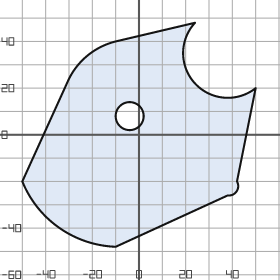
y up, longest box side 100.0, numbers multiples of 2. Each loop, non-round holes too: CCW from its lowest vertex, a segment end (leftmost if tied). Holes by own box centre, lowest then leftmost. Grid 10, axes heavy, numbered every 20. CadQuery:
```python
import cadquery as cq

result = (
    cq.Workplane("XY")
    .moveTo(-10.0, -48.0)
    .lineTo(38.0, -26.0)
    .threePointArc((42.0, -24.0), (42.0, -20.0))
    .lineTo(50.0, 20.0)
    .threePointArc((24.0, 22.0), (24.0, 48.0))
    .lineTo(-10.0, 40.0)
    .threePointArc((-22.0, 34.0), (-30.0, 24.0))
    .lineTo(-50.0, -20.0)
    .threePointArc((-34.0, -40.0), (-10.0, -48.0))
    .close()
    .moveTo(-4.0, 8.0)
    .circle(6.0)
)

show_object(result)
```